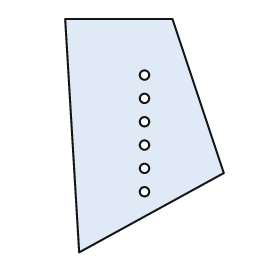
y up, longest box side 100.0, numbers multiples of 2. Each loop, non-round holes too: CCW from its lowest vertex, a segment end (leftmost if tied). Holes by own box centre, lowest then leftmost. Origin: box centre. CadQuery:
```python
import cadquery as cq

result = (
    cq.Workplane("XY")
    .moveTo(-28.0, -50.0)
    .lineTo(34.0, -16.0)
    .lineTo(12.0, 50.0)
    .lineTo(-34.0, 50.0)
    .close()
    .moveTo(0.0, -24.0)
    .circle(2.0)
    .moveTo(0.0, -14.0)
    .circle(2.0)
    .moveTo(0.0, -4.0)
    .circle(2.0)
    .moveTo(0.0, 6.0)
    .circle(2.0)
    .moveTo(0.0, 16.0)
    .circle(2.0)
    .moveTo(0.0, 26.0)
    .circle(2.0)
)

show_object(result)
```